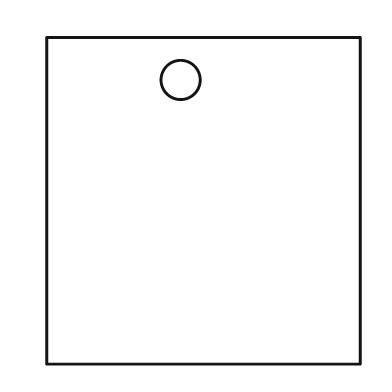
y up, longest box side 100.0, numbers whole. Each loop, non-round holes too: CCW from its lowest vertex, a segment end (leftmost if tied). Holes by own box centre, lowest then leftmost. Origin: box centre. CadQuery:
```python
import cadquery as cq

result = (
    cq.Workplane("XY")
    .moveTo(-48.0, -50.0)
    .lineTo(48.0, -50.0)
    .lineTo(48.0, 50.0)
    .lineTo(-48.0, 50.0)
    .close()
    .moveTo(-7.0, 37.0)
    .circle(6.0)
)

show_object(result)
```